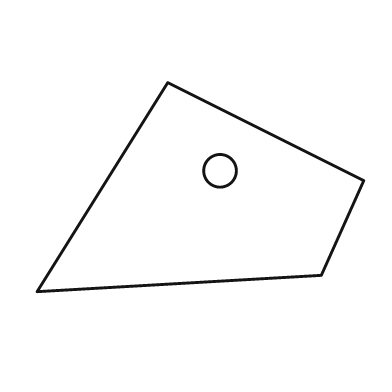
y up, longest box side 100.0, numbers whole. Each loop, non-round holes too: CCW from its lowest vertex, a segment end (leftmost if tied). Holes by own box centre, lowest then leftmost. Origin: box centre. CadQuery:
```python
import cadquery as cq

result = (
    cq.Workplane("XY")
    .moveTo(-50.0, -32.0)
    .lineTo(37.0, -27.0)
    .lineTo(50.0, 2.0)
    .lineTo(-10.0, 32.0)
    .close()
    .moveTo(6.0, 5.0)
    .circle(5.0)
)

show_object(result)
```